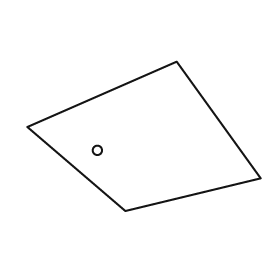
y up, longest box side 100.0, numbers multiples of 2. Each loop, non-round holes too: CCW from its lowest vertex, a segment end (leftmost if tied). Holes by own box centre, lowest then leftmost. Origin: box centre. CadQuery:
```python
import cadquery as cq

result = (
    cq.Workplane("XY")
    .moveTo(-8.0, -32.0)
    .lineTo(50.0, -18.0)
    .lineTo(14.0, 32.0)
    .lineTo(-50.0, 4.0)
    .close()
    .moveTo(-20.0, -6.0)
    .circle(2.0)
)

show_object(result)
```